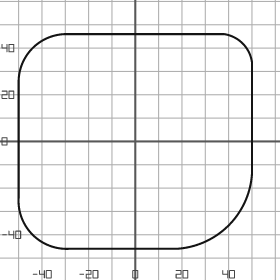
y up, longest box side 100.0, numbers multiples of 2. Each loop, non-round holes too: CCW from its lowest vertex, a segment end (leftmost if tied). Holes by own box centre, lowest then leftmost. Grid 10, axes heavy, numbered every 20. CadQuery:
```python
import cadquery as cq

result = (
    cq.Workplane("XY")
    .moveTo(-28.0, -46.0)
    .lineTo(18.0, -46.0)
    .threePointArc((40.0, -36.0), (50.0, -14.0))
    .lineTo(50.0, 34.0)
    .threePointArc((46.0, 42.0), (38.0, 46.0))
    .lineTo(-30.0, 46.0)
    .threePointArc((-44.0, 40.0), (-50.0, 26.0))
    .lineTo(-50.0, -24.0)
    .threePointArc((-44.0, -40.0), (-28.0, -46.0))
    .close()
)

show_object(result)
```